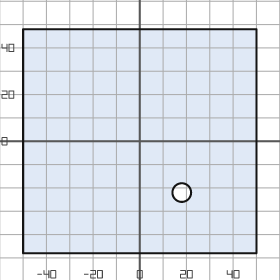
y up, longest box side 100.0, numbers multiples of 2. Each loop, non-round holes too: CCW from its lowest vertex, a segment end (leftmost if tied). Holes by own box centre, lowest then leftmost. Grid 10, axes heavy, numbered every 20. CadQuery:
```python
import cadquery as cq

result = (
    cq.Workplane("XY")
    .moveTo(-50.0, -48.0)
    .lineTo(50.0, -48.0)
    .lineTo(50.0, 48.0)
    .lineTo(-50.0, 48.0)
    .close()
    .moveTo(18.0, -22.0)
    .circle(4.0)
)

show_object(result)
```